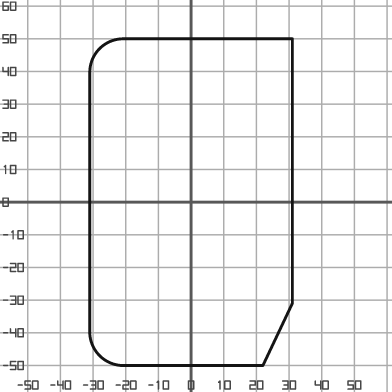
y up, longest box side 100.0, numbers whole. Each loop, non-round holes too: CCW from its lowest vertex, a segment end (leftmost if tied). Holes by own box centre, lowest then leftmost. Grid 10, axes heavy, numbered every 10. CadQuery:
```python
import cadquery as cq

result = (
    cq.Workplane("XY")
    .moveTo(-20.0, -50.0)
    .lineTo(22.0, -50.0)
    .lineTo(31.0, -31.0)
    .lineTo(31.0, 50.0)
    .lineTo(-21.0, 50.0)
    .threePointArc((-28.0, 47.0), (-31.0, 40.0))
    .lineTo(-31.0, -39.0)
    .threePointArc((-28.0, -47.0), (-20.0, -50.0))
    .close()
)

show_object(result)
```